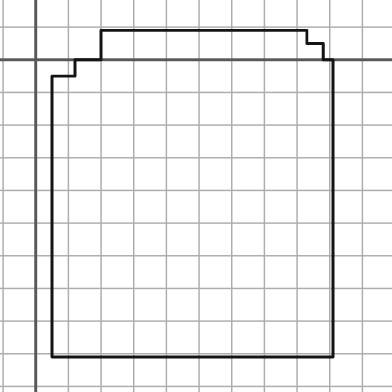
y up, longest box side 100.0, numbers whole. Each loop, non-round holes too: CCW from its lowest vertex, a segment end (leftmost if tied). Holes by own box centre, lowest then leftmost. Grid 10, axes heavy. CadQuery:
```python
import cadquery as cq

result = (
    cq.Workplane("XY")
    .moveTo(5.0, -91.0)
    .lineTo(91.0, -91.0)
    .lineTo(91.0, 0.0)
    .lineTo(88.0, 0.0)
    .lineTo(88.0, 5.0)
    .lineTo(83.0, 5.0)
    .lineTo(83.0, 9.0)
    .lineTo(20.0, 9.0)
    .lineTo(20.0, 0.0)
    .lineTo(12.0, 0.0)
    .lineTo(12.0, -5.0)
    .lineTo(5.0, -5.0)
    .close()
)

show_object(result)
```